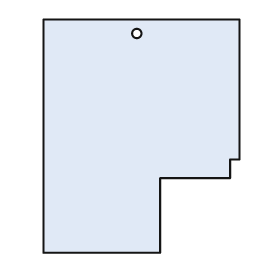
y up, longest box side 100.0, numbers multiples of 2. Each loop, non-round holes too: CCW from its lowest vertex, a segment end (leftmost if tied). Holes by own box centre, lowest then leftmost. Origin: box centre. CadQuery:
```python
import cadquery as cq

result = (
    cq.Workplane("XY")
    .moveTo(-42.0, -50.0)
    .lineTo(8.0, -50.0)
    .lineTo(8.0, -18.0)
    .lineTo(38.0, -18.0)
    .lineTo(38.0, -10.0)
    .lineTo(42.0, -10.0)
    .lineTo(42.0, 50.0)
    .lineTo(-42.0, 50.0)
    .close()
    .moveTo(-2.0, 44.0)
    .circle(2.0)
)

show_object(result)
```